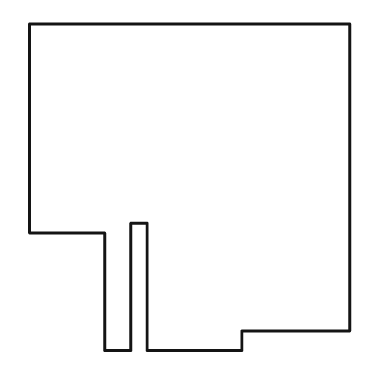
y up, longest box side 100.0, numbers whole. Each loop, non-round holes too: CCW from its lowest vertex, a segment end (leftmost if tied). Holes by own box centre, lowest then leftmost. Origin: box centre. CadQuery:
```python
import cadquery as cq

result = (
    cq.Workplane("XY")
    .moveTo(-26.0, -50.0)
    .lineTo(-18.0, -50.0)
    .lineTo(-18.0, -11.0)
    .lineTo(-13.0, -11.0)
    .lineTo(-13.0, -50.0)
    .lineTo(16.0, -50.0)
    .lineTo(16.0, -44.0)
    .lineTo(49.0, -44.0)
    .lineTo(49.0, 50.0)
    .lineTo(-49.0, 50.0)
    .lineTo(-49.0, -14.0)
    .lineTo(-26.0, -14.0)
    .close()
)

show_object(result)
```